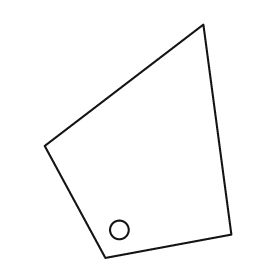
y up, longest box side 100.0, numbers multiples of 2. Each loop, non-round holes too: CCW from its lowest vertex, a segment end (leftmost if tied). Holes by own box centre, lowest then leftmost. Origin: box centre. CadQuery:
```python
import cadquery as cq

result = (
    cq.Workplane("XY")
    .moveTo(-14.0, -50.0)
    .lineTo(40.0, -40.0)
    .lineTo(28.0, 50.0)
    .lineTo(-40.0, -2.0)
    .close()
    .moveTo(-8.0, -38.0)
    .circle(4.0)
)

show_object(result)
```